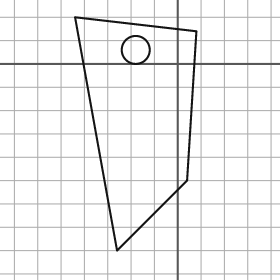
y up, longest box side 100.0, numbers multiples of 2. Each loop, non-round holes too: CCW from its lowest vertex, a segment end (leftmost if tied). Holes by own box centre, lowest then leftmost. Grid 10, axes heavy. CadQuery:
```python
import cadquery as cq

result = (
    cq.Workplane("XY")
    .moveTo(-26.0, -80.0)
    .lineTo(4.0, -50.0)
    .lineTo(8.0, 14.0)
    .lineTo(-44.0, 20.0)
    .close()
    .moveTo(-18.0, 6.0)
    .circle(6.0)
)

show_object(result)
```